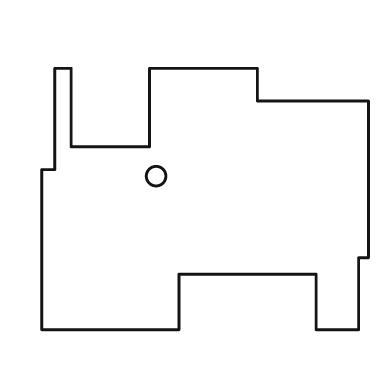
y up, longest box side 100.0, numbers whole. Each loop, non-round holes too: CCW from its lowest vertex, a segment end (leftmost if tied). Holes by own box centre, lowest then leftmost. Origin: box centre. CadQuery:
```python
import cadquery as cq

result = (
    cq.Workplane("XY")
    .moveTo(-50.0, -40.0)
    .lineTo(-8.0, -40.0)
    .lineTo(-8.0, -23.0)
    .lineTo(34.0, -23.0)
    .lineTo(34.0, -40.0)
    .lineTo(47.0, -40.0)
    .lineTo(47.0, -18.0)
    .lineTo(50.0, -18.0)
    .lineTo(50.0, 30.0)
    .lineTo(16.0, 30.0)
    .lineTo(16.0, 40.0)
    .lineTo(-17.0, 40.0)
    .lineTo(-17.0, 16.0)
    .lineTo(-41.0, 16.0)
    .lineTo(-41.0, 40.0)
    .lineTo(-46.0, 40.0)
    .lineTo(-46.0, 9.0)
    .lineTo(-50.0, 9.0)
    .close()
    .moveTo(-15.0, 7.0)
    .circle(3.0)
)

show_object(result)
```